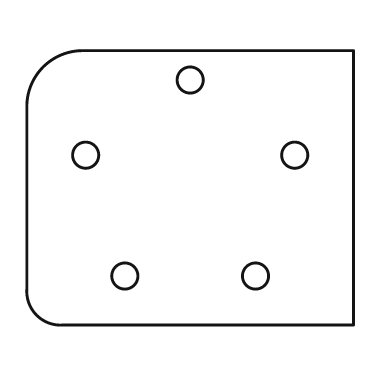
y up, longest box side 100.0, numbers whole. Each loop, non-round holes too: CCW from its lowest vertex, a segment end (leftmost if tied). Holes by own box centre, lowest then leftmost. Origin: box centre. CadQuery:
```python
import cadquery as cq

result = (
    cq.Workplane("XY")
    .moveTo(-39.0, -42.0)
    .lineTo(50.0, -42.0)
    .lineTo(50.0, 42.0)
    .lineTo(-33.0, 42.0)
    .threePointArc((-45.0, 37.0), (-50.0, 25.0))
    .lineTo(-50.0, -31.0)
    .threePointArc((-47.0, -39.0), (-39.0, -42.0))
    .close()
    .moveTo(-20.0, -27.0)
    .circle(4.0)
    .moveTo(20.0, -27.0)
    .circle(4.0)
    .moveTo(-32.0, 10.0)
    .circle(4.0)
    .moveTo(32.0, 10.0)
    .circle(4.0)
    .moveTo(0.0, 33.0)
    .circle(4.0)
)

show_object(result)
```